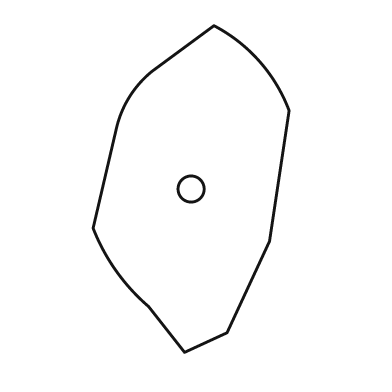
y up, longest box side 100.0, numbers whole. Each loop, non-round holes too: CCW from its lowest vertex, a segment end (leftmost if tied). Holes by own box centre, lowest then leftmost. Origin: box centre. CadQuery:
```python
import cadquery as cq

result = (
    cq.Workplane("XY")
    .moveTo(-2.0, -50.0)
    .lineTo(11.0, -44.0)
    .lineTo(24.0, -16.0)
    .lineTo(30.0, 24.0)
    .threePointArc((21.0, 39.0), (7.0, 50.0))
    .lineTo(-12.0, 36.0)
    .threePointArc((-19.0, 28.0), (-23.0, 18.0))
    .lineTo(-30.0, -12.0)
    .threePointArc((-23.0, -25.0), (-13.0, -36.0))
    .close()
    .moveTo(0.0, 0.0)
    .circle(4.0)
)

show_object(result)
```